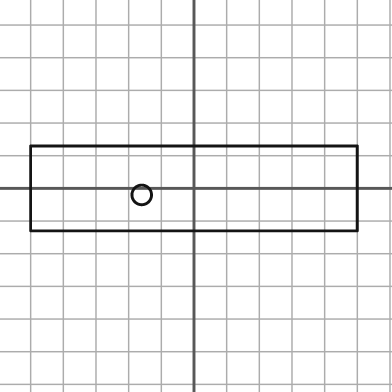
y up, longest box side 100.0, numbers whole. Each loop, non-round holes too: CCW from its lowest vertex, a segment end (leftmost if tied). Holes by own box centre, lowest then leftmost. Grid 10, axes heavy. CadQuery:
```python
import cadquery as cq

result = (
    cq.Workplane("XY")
    .moveTo(-50.0, -13.0)
    .lineTo(50.0, -13.0)
    .lineTo(50.0, 13.0)
    .lineTo(-50.0, 13.0)
    .close()
    .moveTo(-16.0, -2.0)
    .circle(3.0)
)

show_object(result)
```